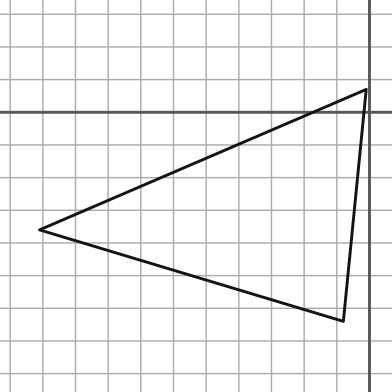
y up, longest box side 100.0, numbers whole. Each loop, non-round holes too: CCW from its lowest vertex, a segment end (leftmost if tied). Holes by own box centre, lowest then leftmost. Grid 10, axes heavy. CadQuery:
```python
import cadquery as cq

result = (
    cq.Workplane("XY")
    .moveTo(-8.0, -64.0)
    .lineTo(-1.0, 7.0)
    .lineTo(-101.0, -36.0)
    .close()
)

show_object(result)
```